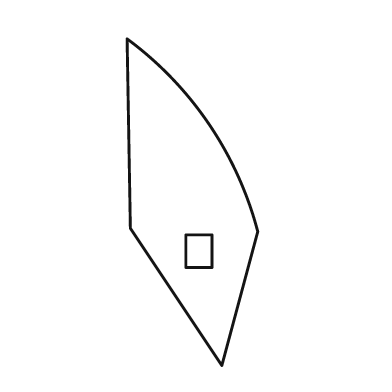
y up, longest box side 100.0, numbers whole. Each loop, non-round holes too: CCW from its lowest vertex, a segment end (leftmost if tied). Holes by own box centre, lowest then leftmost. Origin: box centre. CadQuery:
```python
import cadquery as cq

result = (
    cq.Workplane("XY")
    .moveTo(9.0, -50.0)
    .lineTo(20.0, -9.0)
    .threePointArc((5.0, 24.0), (-20.0, 50.0))
    .lineTo(-19.0, -8.0)
    .close()
    .moveTo(-2.0, -20.0)
    .lineTo(6.0, -20.0)
    .lineTo(6.0, -10.0)
    .lineTo(-2.0, -10.0)
    .close()
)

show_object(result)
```